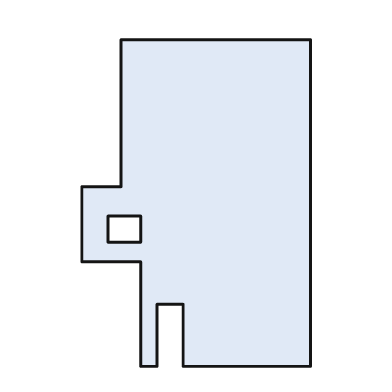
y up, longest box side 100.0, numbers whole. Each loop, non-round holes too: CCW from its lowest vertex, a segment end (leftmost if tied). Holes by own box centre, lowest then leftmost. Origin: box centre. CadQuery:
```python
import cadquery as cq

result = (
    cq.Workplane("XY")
    .moveTo(-17.0, -50.0)
    .lineTo(-12.0, -50.0)
    .lineTo(-12.0, -31.0)
    .lineTo(-4.0, -31.0)
    .lineTo(-4.0, -50.0)
    .lineTo(35.0, -50.0)
    .lineTo(35.0, 50.0)
    .lineTo(-23.0, 50.0)
    .lineTo(-23.0, 5.0)
    .lineTo(-35.0, 5.0)
    .lineTo(-35.0, -18.0)
    .lineTo(-17.0, -18.0)
    .close()
    .moveTo(-27.0, -12.0)
    .lineTo(-17.0, -12.0)
    .lineTo(-17.0, -4.0)
    .lineTo(-27.0, -4.0)
    .close()
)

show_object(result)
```